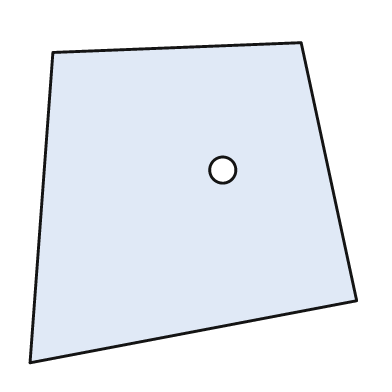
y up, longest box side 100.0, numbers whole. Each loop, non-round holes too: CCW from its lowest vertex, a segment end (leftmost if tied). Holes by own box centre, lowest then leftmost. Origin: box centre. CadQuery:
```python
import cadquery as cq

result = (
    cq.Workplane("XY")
    .moveTo(-50.0, -49.0)
    .lineTo(50.0, -30.0)
    .lineTo(33.0, 49.0)
    .lineTo(-43.0, 46.0)
    .close()
    .moveTo(9.0, 10.0)
    .circle(4.0)
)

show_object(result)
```